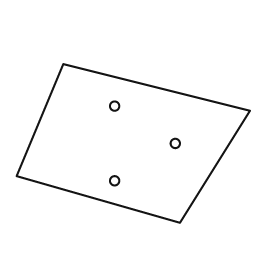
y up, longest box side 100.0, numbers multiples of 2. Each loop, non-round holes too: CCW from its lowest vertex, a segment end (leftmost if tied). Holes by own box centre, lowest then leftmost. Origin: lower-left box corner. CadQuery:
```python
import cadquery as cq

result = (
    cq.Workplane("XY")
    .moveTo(70.0, 0.0)
    .lineTo(100.0, 48.0)
    .lineTo(20.0, 68.0)
    .lineTo(0.0, 20.0)
    .close()
    .moveTo(42.0, 18.0)
    .circle(2.0)
    .moveTo(68.0, 34.0)
    .circle(2.0)
    .moveTo(42.0, 50.0)
    .circle(2.0)
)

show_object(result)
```